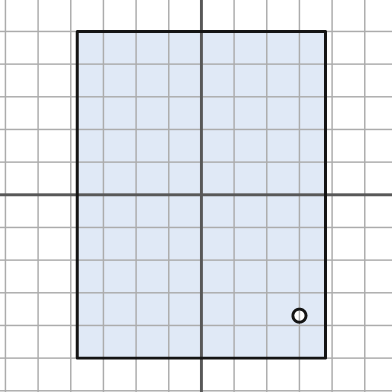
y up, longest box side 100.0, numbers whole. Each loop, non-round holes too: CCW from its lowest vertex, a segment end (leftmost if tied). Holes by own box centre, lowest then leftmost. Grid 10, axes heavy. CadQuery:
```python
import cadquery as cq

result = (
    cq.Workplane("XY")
    .moveTo(-38.0, -50.0)
    .lineTo(38.0, -50.0)
    .lineTo(38.0, 50.0)
    .lineTo(-38.0, 50.0)
    .close()
    .moveTo(30.0, -37.0)
    .circle(2.0)
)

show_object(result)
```